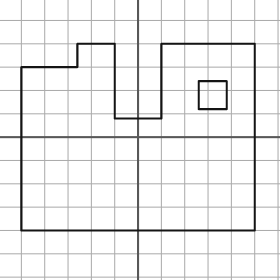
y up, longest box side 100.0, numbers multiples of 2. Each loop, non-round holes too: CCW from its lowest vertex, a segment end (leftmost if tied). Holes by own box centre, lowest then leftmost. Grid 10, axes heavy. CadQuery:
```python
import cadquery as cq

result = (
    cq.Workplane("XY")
    .moveTo(-50.0, -40.0)
    .lineTo(50.0, -40.0)
    .lineTo(50.0, 40.0)
    .lineTo(10.0, 40.0)
    .lineTo(10.0, 8.0)
    .lineTo(-10.0, 8.0)
    .lineTo(-10.0, 40.0)
    .lineTo(-26.0, 40.0)
    .lineTo(-26.0, 30.0)
    .lineTo(-50.0, 30.0)
    .close()
    .moveTo(26.0, 12.0)
    .lineTo(38.0, 12.0)
    .lineTo(38.0, 24.0)
    .lineTo(26.0, 24.0)
    .close()
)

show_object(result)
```